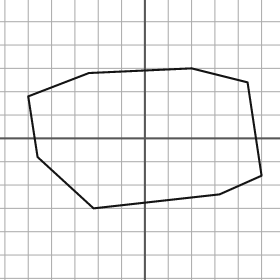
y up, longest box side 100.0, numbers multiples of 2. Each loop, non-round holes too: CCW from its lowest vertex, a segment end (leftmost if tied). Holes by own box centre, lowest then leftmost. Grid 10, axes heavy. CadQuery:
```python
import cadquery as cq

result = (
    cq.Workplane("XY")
    .moveTo(-22.0, -30.0)
    .lineTo(32.0, -24.0)
    .lineTo(50.0, -16.0)
    .lineTo(44.0, 24.0)
    .lineTo(20.0, 30.0)
    .lineTo(-24.0, 28.0)
    .lineTo(-50.0, 18.0)
    .lineTo(-46.0, -8.0)
    .close()
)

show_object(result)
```